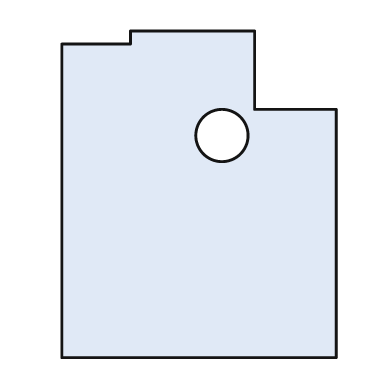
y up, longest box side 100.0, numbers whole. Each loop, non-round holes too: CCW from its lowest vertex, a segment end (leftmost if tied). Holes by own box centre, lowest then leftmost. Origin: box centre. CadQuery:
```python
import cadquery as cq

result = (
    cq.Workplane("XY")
    .moveTo(-42.0, -50.0)
    .lineTo(42.0, -50.0)
    .lineTo(42.0, 26.0)
    .lineTo(17.0, 26.0)
    .lineTo(17.0, 50.0)
    .lineTo(-21.0, 50.0)
    .lineTo(-21.0, 46.0)
    .lineTo(-42.0, 46.0)
    .close()
    .moveTo(7.0, 18.0)
    .circle(8.0)
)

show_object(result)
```